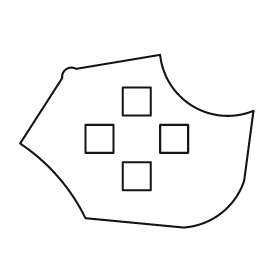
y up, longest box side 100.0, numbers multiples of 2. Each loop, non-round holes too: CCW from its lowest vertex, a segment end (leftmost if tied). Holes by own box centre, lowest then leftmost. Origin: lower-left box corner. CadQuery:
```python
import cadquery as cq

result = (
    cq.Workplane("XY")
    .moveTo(70.0, 0.0)
    .threePointArc((86.0, 6.0), (96.0, 20.0))
    .lineTo(100.0, 50.0)
    .threePointArc((74.0, 52.0), (60.0, 74.0))
    .lineTo(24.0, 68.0)
    .threePointArc((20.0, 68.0), (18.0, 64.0))
    .lineTo(0.0, 36.0)
    .threePointArc((16.0, 22.0), (28.0, 4.0))
    .close()
    .moveTo(44.0, 16.0)
    .lineTo(56.0, 16.0)
    .lineTo(56.0, 28.0)
    .lineTo(44.0, 28.0)
    .close()
    .moveTo(28.0, 32.0)
    .lineTo(40.0, 32.0)
    .lineTo(40.0, 44.0)
    .lineTo(28.0, 44.0)
    .close()
    .moveTo(60.0, 32.0)
    .lineTo(72.0, 32.0)
    .lineTo(72.0, 44.0)
    .lineTo(60.0, 44.0)
    .close()
    .moveTo(44.0, 48.0)
    .lineTo(56.0, 48.0)
    .lineTo(56.0, 60.0)
    .lineTo(44.0, 60.0)
    .close()
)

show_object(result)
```